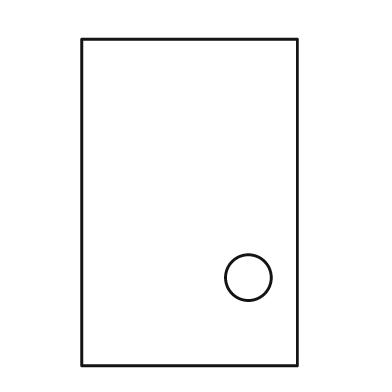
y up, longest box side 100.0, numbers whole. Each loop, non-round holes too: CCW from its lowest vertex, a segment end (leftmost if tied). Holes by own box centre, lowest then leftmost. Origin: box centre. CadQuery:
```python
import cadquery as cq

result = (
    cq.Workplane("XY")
    .moveTo(-33.0, -50.0)
    .lineTo(33.0, -50.0)
    .lineTo(33.0, 50.0)
    .lineTo(-33.0, 50.0)
    .close()
    .moveTo(18.0, -23.0)
    .circle(7.0)
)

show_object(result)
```